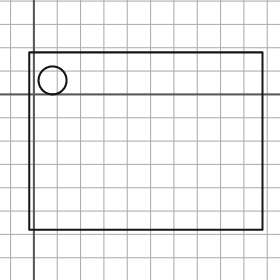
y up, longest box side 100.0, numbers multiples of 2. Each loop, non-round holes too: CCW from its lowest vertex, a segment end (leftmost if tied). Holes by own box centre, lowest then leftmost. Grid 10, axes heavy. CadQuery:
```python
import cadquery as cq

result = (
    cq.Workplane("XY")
    .moveTo(-2.0, -58.0)
    .lineTo(98.0, -58.0)
    .lineTo(98.0, 18.0)
    .lineTo(-2.0, 18.0)
    .close()
    .moveTo(8.0, 6.0)
    .circle(6.0)
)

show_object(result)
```